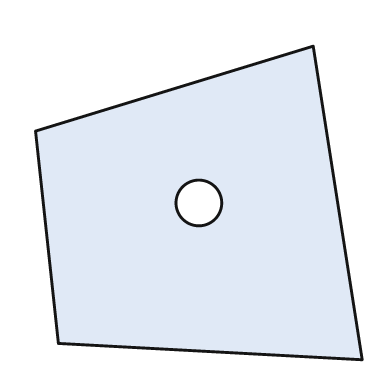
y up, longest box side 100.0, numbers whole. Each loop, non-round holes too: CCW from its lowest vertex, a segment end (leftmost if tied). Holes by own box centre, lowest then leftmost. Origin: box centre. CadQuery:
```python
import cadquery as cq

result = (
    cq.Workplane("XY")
    .moveTo(50.0, -48.0)
    .lineTo(35.0, 48.0)
    .lineTo(-50.0, 22.0)
    .lineTo(-43.0, -43.0)
    .close()
    .moveTo(0.0, 0.0)
    .circle(7.0)
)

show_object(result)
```